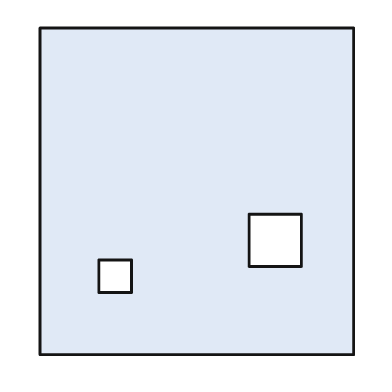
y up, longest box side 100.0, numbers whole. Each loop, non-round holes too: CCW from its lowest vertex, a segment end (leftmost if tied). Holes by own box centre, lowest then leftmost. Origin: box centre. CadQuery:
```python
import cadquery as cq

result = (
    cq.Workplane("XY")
    .moveTo(-48.0, -50.0)
    .lineTo(48.0, -50.0)
    .lineTo(48.0, 50.0)
    .lineTo(-48.0, 50.0)
    .close()
    .moveTo(-30.0, -31.0)
    .lineTo(-20.0, -31.0)
    .lineTo(-20.0, -21.0)
    .lineTo(-30.0, -21.0)
    .close()
    .moveTo(16.0, -23.0)
    .lineTo(32.0, -23.0)
    .lineTo(32.0, -7.0)
    .lineTo(16.0, -7.0)
    .close()
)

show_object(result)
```